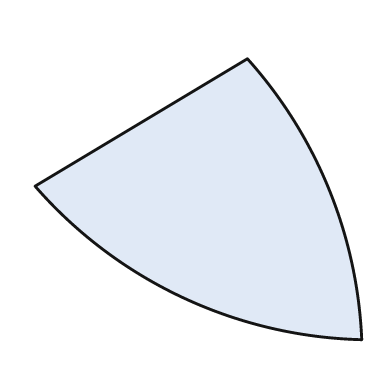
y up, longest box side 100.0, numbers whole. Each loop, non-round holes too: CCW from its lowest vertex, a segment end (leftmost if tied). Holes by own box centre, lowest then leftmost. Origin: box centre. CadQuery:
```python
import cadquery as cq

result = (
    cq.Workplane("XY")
    .moveTo(50.0, -43.0)
    .threePointArc((40.0, 3.0), (15.0, 43.0))
    .lineTo(-50.0, 4.0)
    .threePointArc((-5.0, -30.0), (50.0, -43.0))
    .close()
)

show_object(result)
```